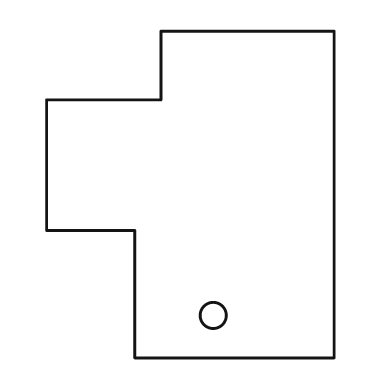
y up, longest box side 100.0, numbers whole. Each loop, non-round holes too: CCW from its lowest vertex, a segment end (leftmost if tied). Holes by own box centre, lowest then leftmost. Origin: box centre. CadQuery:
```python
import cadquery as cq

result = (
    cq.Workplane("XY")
    .moveTo(-17.0, -50.0)
    .lineTo(44.0, -50.0)
    .lineTo(44.0, 50.0)
    .lineTo(-9.0, 50.0)
    .lineTo(-9.0, 29.0)
    .lineTo(-44.0, 29.0)
    .lineTo(-44.0, -11.0)
    .lineTo(-17.0, -11.0)
    .close()
    .moveTo(7.0, -37.0)
    .circle(4.0)
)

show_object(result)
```